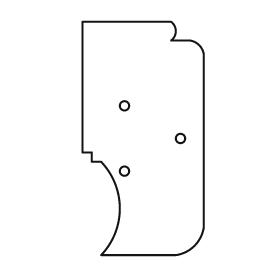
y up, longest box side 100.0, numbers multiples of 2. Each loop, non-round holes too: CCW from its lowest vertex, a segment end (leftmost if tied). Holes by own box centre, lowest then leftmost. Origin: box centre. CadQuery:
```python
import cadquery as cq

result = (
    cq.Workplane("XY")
    .moveTo(-18.0, -50.0)
    .lineTo(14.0, -50.0)
    .threePointArc((22.0, -46.0), (26.0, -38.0))
    .lineTo(26.0, 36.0)
    .threePointArc((24.0, 40.0), (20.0, 42.0))
    .lineTo(12.0, 42.0)
    .threePointArc((14.0, 46.0), (12.0, 50.0))
    .lineTo(-26.0, 50.0)
    .lineTo(-26.0, -6.0)
    .lineTo(-22.0, -6.0)
    .lineTo(-22.0, -10.0)
    .lineTo(-18.0, -10.0)
    .threePointArc((-10.0, -30.0), (-18.0, -50.0))
    .close()
    .moveTo(-8.0, -14.0)
    .circle(2.0)
    .moveTo(16.0, 0.0)
    .circle(2.0)
    .moveTo(-8.0, 14.0)
    .circle(2.0)
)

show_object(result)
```